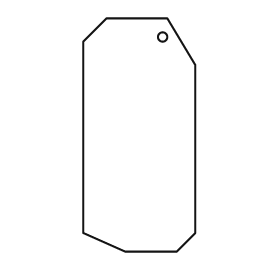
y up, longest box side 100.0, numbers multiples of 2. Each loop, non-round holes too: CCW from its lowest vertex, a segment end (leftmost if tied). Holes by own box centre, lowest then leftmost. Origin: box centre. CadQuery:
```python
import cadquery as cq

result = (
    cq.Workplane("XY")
    .moveTo(-6.0, -50.0)
    .lineTo(16.0, -50.0)
    .lineTo(24.0, -42.0)
    .lineTo(24.0, 30.0)
    .lineTo(12.0, 50.0)
    .lineTo(-14.0, 50.0)
    .lineTo(-24.0, 40.0)
    .lineTo(-24.0, -42.0)
    .close()
    .moveTo(10.0, 42.0)
    .circle(2.0)
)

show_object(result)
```